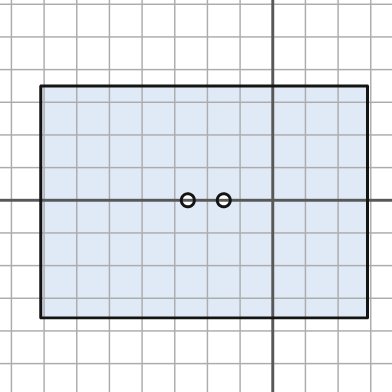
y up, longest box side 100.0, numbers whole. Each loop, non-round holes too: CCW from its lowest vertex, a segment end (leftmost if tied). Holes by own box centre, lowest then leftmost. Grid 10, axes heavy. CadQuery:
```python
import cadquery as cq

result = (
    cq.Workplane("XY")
    .moveTo(-71.0, -36.0)
    .lineTo(29.0, -36.0)
    .lineTo(29.0, 35.0)
    .lineTo(-71.0, 35.0)
    .close()
    .moveTo(-26.0, 0.0)
    .circle(2.0)
    .moveTo(-15.0, 0.0)
    .circle(2.0)
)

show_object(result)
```